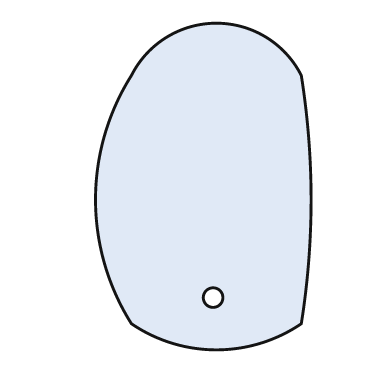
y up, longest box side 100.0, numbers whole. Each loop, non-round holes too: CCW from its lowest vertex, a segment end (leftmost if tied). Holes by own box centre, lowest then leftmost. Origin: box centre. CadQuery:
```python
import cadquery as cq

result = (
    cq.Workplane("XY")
    .moveTo(-22.0, -42.0)
    .threePointArc((4.0, -50.0), (30.0, -42.0))
    .threePointArc((33.0, -4.0), (30.0, 34.0))
    .threePointArc((4.0, 50.0), (-22.0, 34.0))
    .threePointArc((-33.0, -4.0), (-22.0, -42.0))
    .close()
    .moveTo(3.0, -34.0)
    .circle(3.0)
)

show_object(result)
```